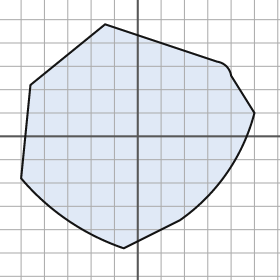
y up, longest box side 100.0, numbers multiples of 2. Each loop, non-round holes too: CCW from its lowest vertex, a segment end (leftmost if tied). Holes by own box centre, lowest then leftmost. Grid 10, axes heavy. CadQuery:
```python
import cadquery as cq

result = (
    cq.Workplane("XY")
    .moveTo(-6.0, -48.0)
    .lineTo(18.0, -36.0)
    .threePointArc((38.0, -16.0), (50.0, 10.0))
    .lineTo(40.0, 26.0)
    .threePointArc((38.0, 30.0), (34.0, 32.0))
    .lineTo(-14.0, 48.0)
    .lineTo(-46.0, 22.0)
    .lineTo(-50.0, -18.0)
    .threePointArc((-30.0, -36.0), (-6.0, -48.0))
    .close()
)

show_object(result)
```